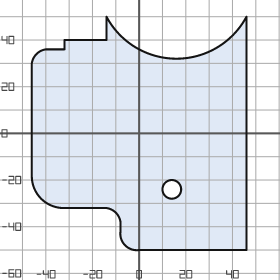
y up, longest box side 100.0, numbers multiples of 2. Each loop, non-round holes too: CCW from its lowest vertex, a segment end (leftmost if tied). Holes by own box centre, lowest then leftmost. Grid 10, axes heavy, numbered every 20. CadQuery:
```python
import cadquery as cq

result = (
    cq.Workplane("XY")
    .moveTo(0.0, -50.0)
    .lineTo(46.0, -50.0)
    .lineTo(46.0, 50.0)
    .threePointArc((16.0, 32.0), (-14.0, 50.0))
    .lineTo(-14.0, 40.0)
    .lineTo(-32.0, 40.0)
    .lineTo(-32.0, 36.0)
    .lineTo(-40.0, 36.0)
    .threePointArc((-44.0, 34.0), (-46.0, 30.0))
    .lineTo(-46.0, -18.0)
    .threePointArc((-42.0, -28.0), (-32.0, -32.0))
    .lineTo(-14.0, -32.0)
    .threePointArc((-10.0, -34.0), (-8.0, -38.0))
    .lineTo(-8.0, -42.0)
    .threePointArc((-6.0, -48.0), (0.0, -50.0))
    .close()
    .moveTo(14.0, -24.0)
    .circle(4.0)
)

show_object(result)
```